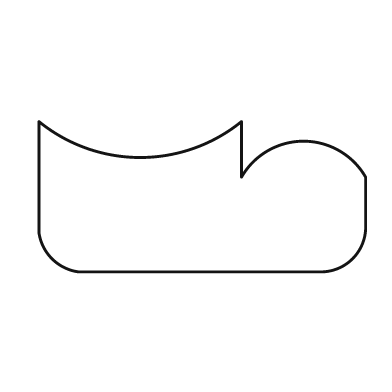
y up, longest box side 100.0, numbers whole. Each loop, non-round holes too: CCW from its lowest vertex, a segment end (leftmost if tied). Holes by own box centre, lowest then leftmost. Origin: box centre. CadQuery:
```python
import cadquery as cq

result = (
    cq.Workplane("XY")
    .moveTo(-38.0, -23.0)
    .lineTo(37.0, -23.0)
    .threePointArc((46.0, -19.0), (50.0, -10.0))
    .lineTo(50.0, 6.0)
    .threePointArc((31.0, 17.0), (12.0, 6.0))
    .lineTo(12.0, 23.0)
    .threePointArc((-19.0, 12.0), (-50.0, 23.0))
    .lineTo(-50.0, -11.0)
    .threePointArc((-46.0, -19.0), (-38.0, -23.0))
    .close()
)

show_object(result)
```